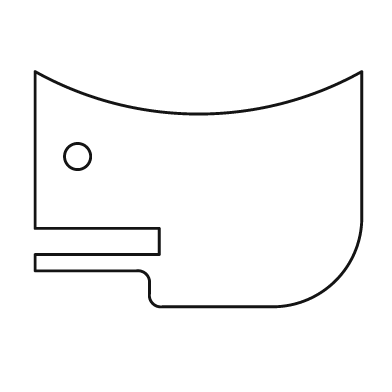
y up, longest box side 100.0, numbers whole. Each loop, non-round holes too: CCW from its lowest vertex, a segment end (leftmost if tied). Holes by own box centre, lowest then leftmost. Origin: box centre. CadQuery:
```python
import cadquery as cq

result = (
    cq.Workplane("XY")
    .moveTo(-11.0, -36.0)
    .lineTo(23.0, -36.0)
    .threePointArc((42.0, -28.0), (50.0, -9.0))
    .lineTo(50.0, 36.0)
    .threePointArc((0.0, 23.0), (-50.0, 36.0))
    .lineTo(-50.0, -12.0)
    .lineTo(-12.0, -12.0)
    .lineTo(-12.0, -20.0)
    .lineTo(-50.0, -20.0)
    .lineTo(-50.0, -25.0)
    .lineTo(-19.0, -25.0)
    .threePointArc((-16.0, -26.0), (-15.0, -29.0))
    .lineTo(-15.0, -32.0)
    .threePointArc((-14.0, -35.0), (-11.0, -36.0))
    .close()
    .moveTo(-37.0, 10.0)
    .circle(4.0)
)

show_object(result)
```